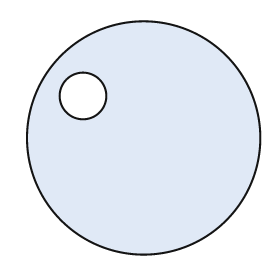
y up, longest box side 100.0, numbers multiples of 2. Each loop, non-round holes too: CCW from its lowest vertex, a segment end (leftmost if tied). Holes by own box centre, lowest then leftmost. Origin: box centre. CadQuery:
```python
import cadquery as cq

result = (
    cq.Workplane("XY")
    .moveTo(0.0, 0.0)
    .circle(50.0)
    .moveTo(-26.0, 18.0)
    .circle(10.0)
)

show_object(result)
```